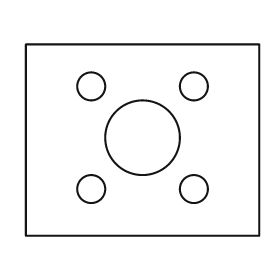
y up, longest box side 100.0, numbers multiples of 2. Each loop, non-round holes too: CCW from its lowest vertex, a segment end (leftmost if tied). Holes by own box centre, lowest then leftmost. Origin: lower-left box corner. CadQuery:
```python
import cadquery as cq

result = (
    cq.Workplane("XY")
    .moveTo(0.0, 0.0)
    .lineTo(100.0, 0.0)
    .lineTo(100.0, 82.0)
    .lineTo(0.0, 82.0)
    .close()
    .moveTo(28.0, 20.0)
    .circle(6.0)
    .moveTo(72.0, 20.0)
    .circle(6.0)
    .moveTo(50.0, 42.0)
    .circle(16.0)
    .moveTo(28.0, 64.0)
    .circle(6.0)
    .moveTo(72.0, 64.0)
    .circle(6.0)
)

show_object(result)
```